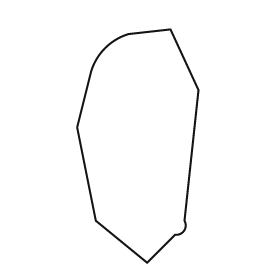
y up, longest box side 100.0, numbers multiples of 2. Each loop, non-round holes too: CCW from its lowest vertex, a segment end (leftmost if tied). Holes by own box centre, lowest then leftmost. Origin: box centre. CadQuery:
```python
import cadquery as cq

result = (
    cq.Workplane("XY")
    .moveTo(4.0, -50.0)
    .lineTo(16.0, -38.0)
    .threePointArc((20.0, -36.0), (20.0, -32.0))
    .lineTo(26.0, 24.0)
    .lineTo(14.0, 50.0)
    .lineTo(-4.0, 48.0)
    .threePointArc((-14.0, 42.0), (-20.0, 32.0))
    .lineTo(-26.0, 8.0)
    .lineTo(-18.0, -32.0)
    .close()
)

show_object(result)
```